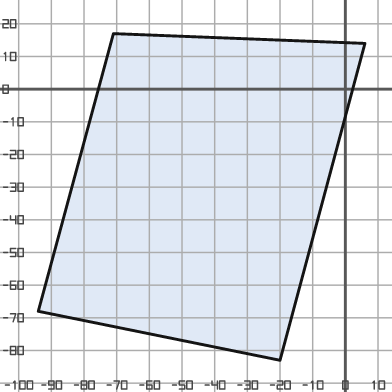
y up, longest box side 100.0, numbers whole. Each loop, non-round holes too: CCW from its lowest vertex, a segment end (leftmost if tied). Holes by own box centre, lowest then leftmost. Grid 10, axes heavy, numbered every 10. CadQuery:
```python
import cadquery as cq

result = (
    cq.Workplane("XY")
    .moveTo(-20.0, -83.0)
    .lineTo(6.0, 14.0)
    .lineTo(-71.0, 17.0)
    .lineTo(-94.0, -68.0)
    .close()
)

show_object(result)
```